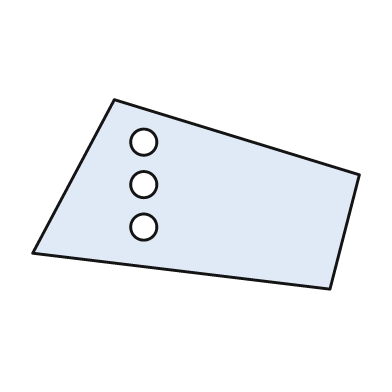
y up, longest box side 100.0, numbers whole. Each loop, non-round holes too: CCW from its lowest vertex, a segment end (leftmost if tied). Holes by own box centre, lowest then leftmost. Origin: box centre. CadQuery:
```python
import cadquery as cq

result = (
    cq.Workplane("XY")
    .moveTo(41.0, -29.0)
    .lineTo(50.0, 6.0)
    .lineTo(-25.0, 29.0)
    .lineTo(-50.0, -18.0)
    .close()
    .moveTo(-16.0, -10.0)
    .circle(4.0)
    .moveTo(-16.0, 3.0)
    .circle(4.0)
    .moveTo(-16.0, 16.0)
    .circle(4.0)
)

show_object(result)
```